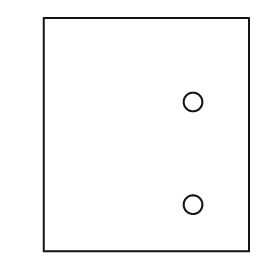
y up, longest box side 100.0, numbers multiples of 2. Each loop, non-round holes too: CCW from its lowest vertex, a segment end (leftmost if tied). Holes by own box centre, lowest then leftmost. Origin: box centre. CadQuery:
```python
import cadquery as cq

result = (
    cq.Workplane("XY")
    .moveTo(-44.0, -50.0)
    .lineTo(44.0, -50.0)
    .lineTo(44.0, 50.0)
    .lineTo(-44.0, 50.0)
    .close()
    .moveTo(20.0, -30.0)
    .circle(4.0)
    .moveTo(20.0, 14.0)
    .circle(4.0)
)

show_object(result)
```